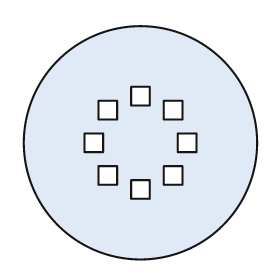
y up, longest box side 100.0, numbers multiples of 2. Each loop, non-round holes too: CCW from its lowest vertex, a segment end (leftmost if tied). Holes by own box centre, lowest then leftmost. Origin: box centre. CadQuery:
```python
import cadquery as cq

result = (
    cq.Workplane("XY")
    .moveTo(0.0, 0.0)
    .circle(50.0)
    .moveTo(-4.0, -24.0)
    .lineTo(4.0, -24.0)
    .lineTo(4.0, -16.0)
    .lineTo(-4.0, -16.0)
    .close()
    .moveTo(-18.0, -18.0)
    .lineTo(-10.0, -18.0)
    .lineTo(-10.0, -10.0)
    .lineTo(-18.0, -10.0)
    .close()
    .moveTo(10.0, -18.0)
    .lineTo(18.0, -18.0)
    .lineTo(18.0, -10.0)
    .lineTo(10.0, -10.0)
    .close()
    .moveTo(-24.0, -4.0)
    .lineTo(-16.0, -4.0)
    .lineTo(-16.0, 4.0)
    .lineTo(-24.0, 4.0)
    .close()
    .moveTo(16.0, -4.0)
    .lineTo(24.0, -4.0)
    .lineTo(24.0, 4.0)
    .lineTo(16.0, 4.0)
    .close()
    .moveTo(-18.0, 10.0)
    .lineTo(-10.0, 10.0)
    .lineTo(-10.0, 18.0)
    .lineTo(-18.0, 18.0)
    .close()
    .moveTo(10.0, 10.0)
    .lineTo(18.0, 10.0)
    .lineTo(18.0, 18.0)
    .lineTo(10.0, 18.0)
    .close()
    .moveTo(-4.0, 16.0)
    .lineTo(4.0, 16.0)
    .lineTo(4.0, 24.0)
    .lineTo(-4.0, 24.0)
    .close()
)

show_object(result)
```